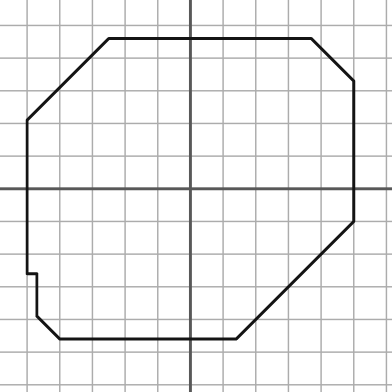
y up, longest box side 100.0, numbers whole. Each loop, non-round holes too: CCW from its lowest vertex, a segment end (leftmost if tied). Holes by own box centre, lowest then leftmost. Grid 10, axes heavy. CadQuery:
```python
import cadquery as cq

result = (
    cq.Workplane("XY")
    .moveTo(-40.0, -46.0)
    .lineTo(14.0, -46.0)
    .lineTo(50.0, -10.0)
    .lineTo(50.0, 33.0)
    .lineTo(37.0, 46.0)
    .lineTo(-25.0, 46.0)
    .lineTo(-50.0, 21.0)
    .lineTo(-50.0, -26.0)
    .lineTo(-47.0, -26.0)
    .lineTo(-47.0, -39.0)
    .close()
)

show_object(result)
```